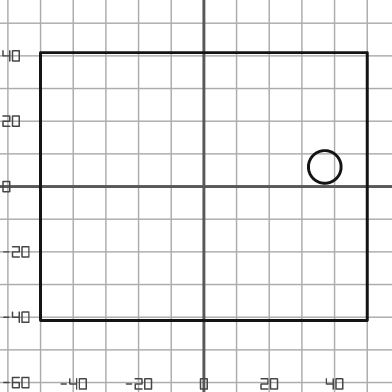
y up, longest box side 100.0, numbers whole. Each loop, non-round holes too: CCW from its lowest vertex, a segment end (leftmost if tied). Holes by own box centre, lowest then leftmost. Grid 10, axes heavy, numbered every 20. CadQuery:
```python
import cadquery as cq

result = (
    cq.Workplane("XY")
    .moveTo(-50.0, -41.0)
    .lineTo(50.0, -41.0)
    .lineTo(50.0, 41.0)
    .lineTo(-50.0, 41.0)
    .close()
    .moveTo(37.0, 6.0)
    .circle(5.0)
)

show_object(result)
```